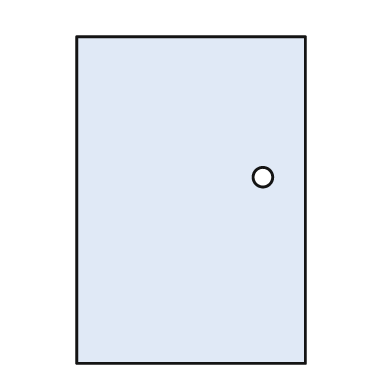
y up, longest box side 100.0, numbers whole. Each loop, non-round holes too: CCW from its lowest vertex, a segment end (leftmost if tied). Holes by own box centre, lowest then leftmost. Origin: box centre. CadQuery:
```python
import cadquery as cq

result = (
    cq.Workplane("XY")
    .moveTo(-35.0, -50.0)
    .lineTo(35.0, -50.0)
    .lineTo(35.0, 50.0)
    .lineTo(-35.0, 50.0)
    .close()
    .moveTo(22.0, 7.0)
    .circle(3.0)
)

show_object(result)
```